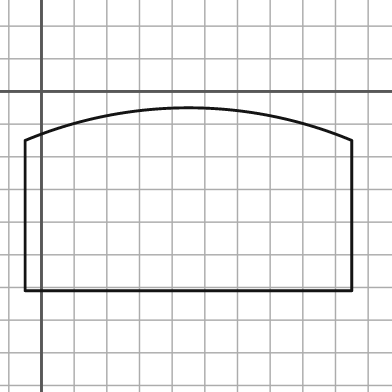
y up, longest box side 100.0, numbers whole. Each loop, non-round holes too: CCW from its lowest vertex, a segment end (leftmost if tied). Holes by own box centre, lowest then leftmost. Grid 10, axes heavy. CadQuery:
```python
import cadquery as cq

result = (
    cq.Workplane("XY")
    .moveTo(-5.0, -61.0)
    .lineTo(95.0, -61.0)
    .lineTo(95.0, -15.0)
    .threePointArc((45.0, -5.0), (-5.0, -15.0))
    .close()
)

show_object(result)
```